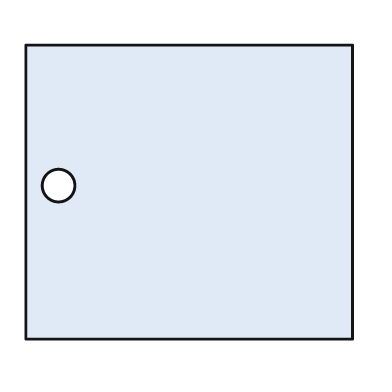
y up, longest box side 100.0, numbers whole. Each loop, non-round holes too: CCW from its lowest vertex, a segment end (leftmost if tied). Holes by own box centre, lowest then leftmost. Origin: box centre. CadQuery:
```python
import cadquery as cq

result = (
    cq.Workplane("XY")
    .moveTo(-50.0, -45.0)
    .lineTo(50.0, -45.0)
    .lineTo(50.0, 45.0)
    .lineTo(-50.0, 45.0)
    .close()
    .moveTo(-40.0, 2.0)
    .circle(5.0)
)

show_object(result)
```